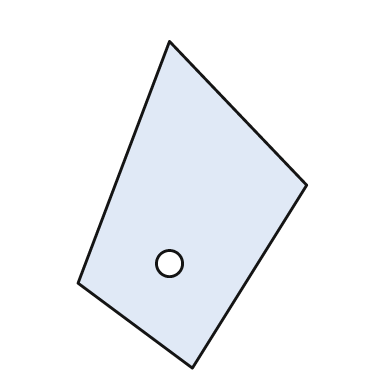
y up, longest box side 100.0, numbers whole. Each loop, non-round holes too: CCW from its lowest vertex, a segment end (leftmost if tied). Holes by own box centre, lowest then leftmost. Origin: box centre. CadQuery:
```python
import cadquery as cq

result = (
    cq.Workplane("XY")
    .moveTo(0.0, -50.0)
    .lineTo(35.0, 6.0)
    .lineTo(-7.0, 50.0)
    .lineTo(-35.0, -24.0)
    .close()
    .moveTo(-7.0, -18.0)
    .circle(4.0)
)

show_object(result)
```